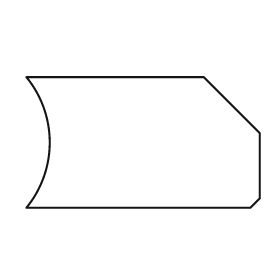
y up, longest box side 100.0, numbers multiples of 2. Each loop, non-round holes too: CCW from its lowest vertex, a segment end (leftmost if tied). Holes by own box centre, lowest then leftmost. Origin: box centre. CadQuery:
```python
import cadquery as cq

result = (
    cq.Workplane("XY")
    .moveTo(-50.0, -28.0)
    .lineTo(46.0, -28.0)
    .lineTo(50.0, -24.0)
    .lineTo(50.0, 4.0)
    .lineTo(26.0, 28.0)
    .lineTo(-50.0, 28.0)
    .threePointArc((-40.0, 0.0), (-50.0, -28.0))
    .close()
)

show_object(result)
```